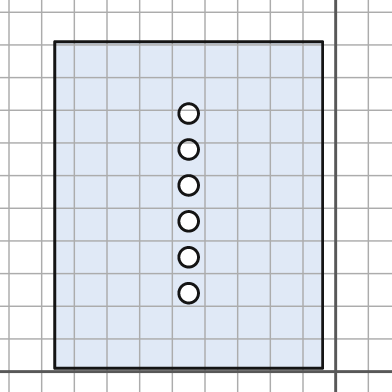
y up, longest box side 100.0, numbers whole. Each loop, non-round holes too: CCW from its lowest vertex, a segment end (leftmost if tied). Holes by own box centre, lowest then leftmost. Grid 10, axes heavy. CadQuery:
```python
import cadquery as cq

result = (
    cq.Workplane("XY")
    .moveTo(-86.0, 1.0)
    .lineTo(-4.0, 1.0)
    .lineTo(-4.0, 101.0)
    .lineTo(-86.0, 101.0)
    .close()
    .moveTo(-45.0, 24.0)
    .circle(3.0)
    .moveTo(-45.0, 35.0)
    .circle(3.0)
    .moveTo(-45.0, 46.0)
    .circle(3.0)
    .moveTo(-45.0, 57.0)
    .circle(3.0)
    .moveTo(-45.0, 68.0)
    .circle(3.0)
    .moveTo(-45.0, 79.0)
    .circle(3.0)
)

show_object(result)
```